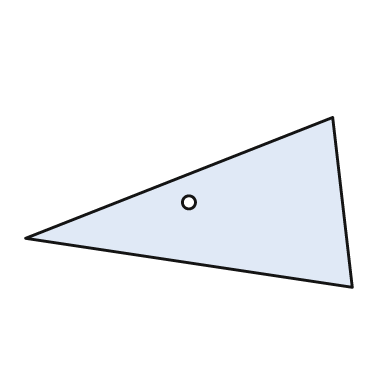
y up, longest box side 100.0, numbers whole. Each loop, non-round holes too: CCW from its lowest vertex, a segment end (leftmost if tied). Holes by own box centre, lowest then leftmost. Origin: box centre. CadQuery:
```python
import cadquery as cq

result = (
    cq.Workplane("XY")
    .moveTo(50.0, -26.0)
    .lineTo(44.0, 26.0)
    .lineTo(-50.0, -11.0)
    .close()
    .moveTo(0.0, 0.0)
    .circle(2.0)
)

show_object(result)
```